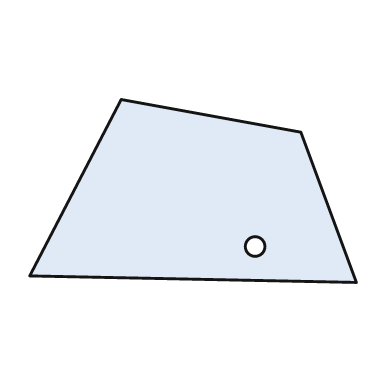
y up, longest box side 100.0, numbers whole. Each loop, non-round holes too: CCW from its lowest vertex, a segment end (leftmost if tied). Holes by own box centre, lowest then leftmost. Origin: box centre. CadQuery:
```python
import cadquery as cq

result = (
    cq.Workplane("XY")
    .moveTo(50.0, -28.0)
    .lineTo(33.0, 18.0)
    .lineTo(-22.0, 28.0)
    .lineTo(-50.0, -26.0)
    .close()
    .moveTo(19.0, -17.0)
    .circle(3.0)
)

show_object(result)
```